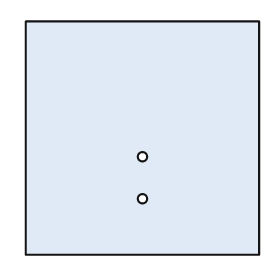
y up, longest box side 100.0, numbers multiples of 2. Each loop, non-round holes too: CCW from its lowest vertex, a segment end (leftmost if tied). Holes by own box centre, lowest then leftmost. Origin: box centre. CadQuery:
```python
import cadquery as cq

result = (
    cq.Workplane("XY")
    .moveTo(-50.0, -50.0)
    .lineTo(50.0, -50.0)
    .lineTo(50.0, 50.0)
    .lineTo(-50.0, 50.0)
    .close()
    .moveTo(0.0, -26.0)
    .circle(2.0)
    .moveTo(0.0, -8.0)
    .circle(2.0)
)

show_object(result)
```